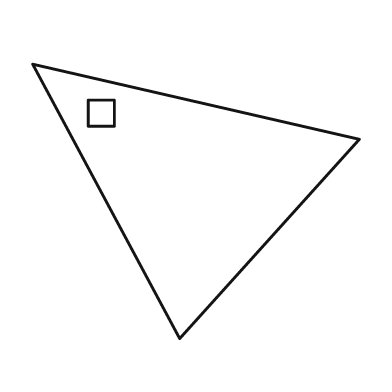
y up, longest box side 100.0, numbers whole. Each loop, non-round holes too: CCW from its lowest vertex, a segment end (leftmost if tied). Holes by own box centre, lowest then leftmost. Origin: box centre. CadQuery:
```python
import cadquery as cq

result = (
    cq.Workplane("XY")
    .moveTo(-5.0, -42.0)
    .lineTo(50.0, 19.0)
    .lineTo(-50.0, 42.0)
    .close()
    .moveTo(-33.0, 23.0)
    .lineTo(-25.0, 23.0)
    .lineTo(-25.0, 31.0)
    .lineTo(-33.0, 31.0)
    .close()
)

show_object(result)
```